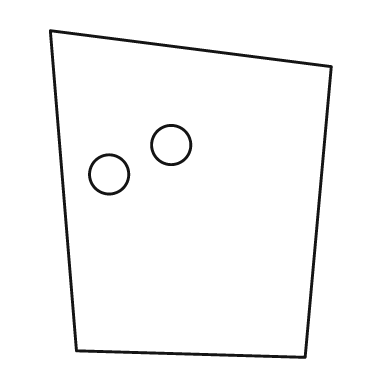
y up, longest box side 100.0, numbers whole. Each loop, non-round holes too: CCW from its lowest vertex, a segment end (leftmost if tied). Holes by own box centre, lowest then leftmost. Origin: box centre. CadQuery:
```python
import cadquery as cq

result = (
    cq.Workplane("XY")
    .moveTo(35.0, -50.0)
    .lineTo(43.0, 39.0)
    .lineTo(-43.0, 50.0)
    .lineTo(-35.0, -48.0)
    .close()
    .moveTo(-25.0, 6.0)
    .circle(6.0)
    .moveTo(-6.0, 15.0)
    .circle(6.0)
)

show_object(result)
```